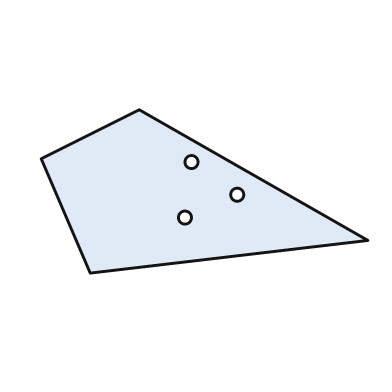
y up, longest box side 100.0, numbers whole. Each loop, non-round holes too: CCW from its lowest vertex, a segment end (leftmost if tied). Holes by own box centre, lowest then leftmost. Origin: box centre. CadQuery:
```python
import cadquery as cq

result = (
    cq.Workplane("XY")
    .moveTo(-35.0, -25.0)
    .lineTo(50.0, -15.0)
    .lineTo(-20.0, 25.0)
    .lineTo(-50.0, 10.0)
    .close()
    .moveTo(-6.0, -8.0)
    .circle(2.0)
    .moveTo(10.0, -1.0)
    .circle(2.0)
    .moveTo(-4.0, 9.0)
    .circle(2.0)
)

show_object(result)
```